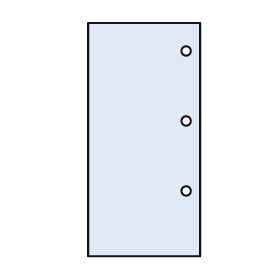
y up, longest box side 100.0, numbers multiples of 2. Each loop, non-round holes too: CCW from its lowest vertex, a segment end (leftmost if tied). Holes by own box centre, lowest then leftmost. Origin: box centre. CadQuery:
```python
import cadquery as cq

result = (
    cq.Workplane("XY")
    .moveTo(-24.0, -50.0)
    .lineTo(24.0, -50.0)
    .lineTo(24.0, 50.0)
    .lineTo(-24.0, 50.0)
    .close()
    .moveTo(18.0, -22.0)
    .circle(2.0)
    .moveTo(18.0, 8.0)
    .circle(2.0)
    .moveTo(18.0, 38.0)
    .circle(2.0)
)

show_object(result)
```